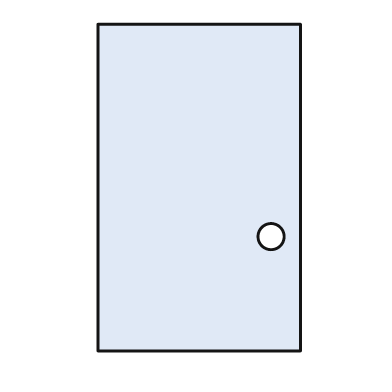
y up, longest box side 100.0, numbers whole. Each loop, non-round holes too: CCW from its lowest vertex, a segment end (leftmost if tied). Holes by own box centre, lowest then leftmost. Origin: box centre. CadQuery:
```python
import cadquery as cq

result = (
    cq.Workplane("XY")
    .moveTo(-31.0, -50.0)
    .lineTo(31.0, -50.0)
    .lineTo(31.0, 50.0)
    .lineTo(-31.0, 50.0)
    .close()
    .moveTo(22.0, -15.0)
    .circle(4.0)
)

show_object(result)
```